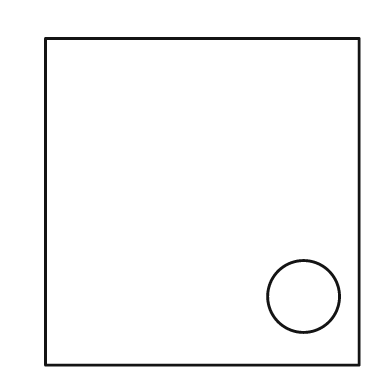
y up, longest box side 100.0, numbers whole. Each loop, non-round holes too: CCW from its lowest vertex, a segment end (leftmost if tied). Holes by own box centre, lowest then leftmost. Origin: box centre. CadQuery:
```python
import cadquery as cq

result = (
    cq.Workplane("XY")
    .moveTo(-48.0, -50.0)
    .lineTo(48.0, -50.0)
    .lineTo(48.0, 50.0)
    .lineTo(-48.0, 50.0)
    .close()
    .moveTo(31.0, -29.0)
    .circle(11.0)
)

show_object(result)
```